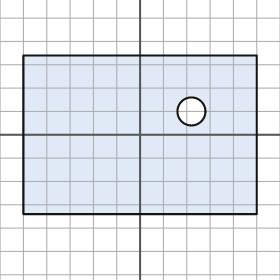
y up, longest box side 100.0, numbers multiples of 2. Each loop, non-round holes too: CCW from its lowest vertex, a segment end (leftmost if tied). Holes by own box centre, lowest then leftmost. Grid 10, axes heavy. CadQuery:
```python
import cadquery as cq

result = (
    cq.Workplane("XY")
    .moveTo(-50.0, -34.0)
    .lineTo(50.0, -34.0)
    .lineTo(50.0, 34.0)
    .lineTo(-50.0, 34.0)
    .close()
    .moveTo(22.0, 10.0)
    .circle(6.0)
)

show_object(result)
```